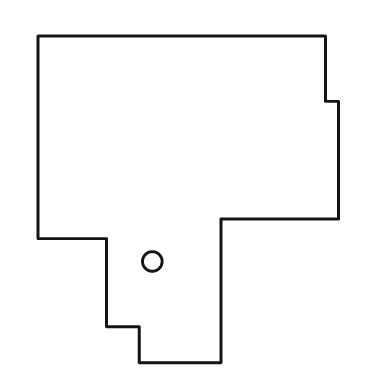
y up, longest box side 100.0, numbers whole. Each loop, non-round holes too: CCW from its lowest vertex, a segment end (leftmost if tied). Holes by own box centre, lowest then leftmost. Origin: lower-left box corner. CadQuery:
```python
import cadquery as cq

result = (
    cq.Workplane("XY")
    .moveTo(31.0, 0.0)
    .lineTo(56.0, 0.0)
    .lineTo(56.0, 44.0)
    .lineTo(92.0, 44.0)
    .lineTo(92.0, 80.0)
    .lineTo(88.0, 80.0)
    .lineTo(88.0, 100.0)
    .lineTo(0.0, 100.0)
    .lineTo(0.0, 38.0)
    .lineTo(21.0, 38.0)
    .lineTo(21.0, 11.0)
    .lineTo(31.0, 11.0)
    .close()
    .moveTo(35.0, 31.0)
    .circle(3.0)
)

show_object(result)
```